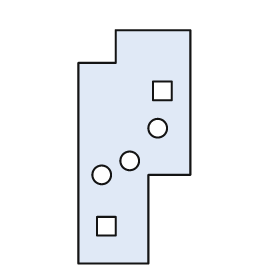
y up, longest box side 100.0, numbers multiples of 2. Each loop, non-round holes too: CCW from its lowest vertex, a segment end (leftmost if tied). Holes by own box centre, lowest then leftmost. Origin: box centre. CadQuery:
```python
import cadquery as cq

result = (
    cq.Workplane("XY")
    .moveTo(-24.0, -50.0)
    .lineTo(6.0, -50.0)
    .lineTo(6.0, -12.0)
    .lineTo(24.0, -12.0)
    .lineTo(24.0, 50.0)
    .lineTo(-8.0, 50.0)
    .lineTo(-8.0, 36.0)
    .lineTo(-24.0, 36.0)
    .close()
    .moveTo(-16.0, -38.0)
    .lineTo(-8.0, -38.0)
    .lineTo(-8.0, -30.0)
    .lineTo(-16.0, -30.0)
    .close()
    .moveTo(-14.0, -12.0)
    .circle(4.0)
    .moveTo(-2.0, -6.0)
    .circle(4.0)
    .moveTo(10.0, 8.0)
    .circle(4.0)
    .moveTo(8.0, 20.0)
    .lineTo(16.0, 20.0)
    .lineTo(16.0, 28.0)
    .lineTo(8.0, 28.0)
    .close()
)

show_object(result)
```